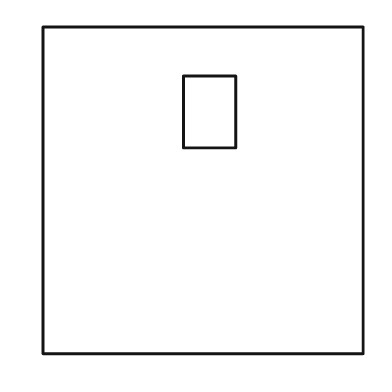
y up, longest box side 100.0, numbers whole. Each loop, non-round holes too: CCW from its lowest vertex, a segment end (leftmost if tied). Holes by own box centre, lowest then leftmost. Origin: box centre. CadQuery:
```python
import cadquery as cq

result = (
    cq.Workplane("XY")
    .moveTo(-49.0, -50.0)
    .lineTo(49.0, -50.0)
    .lineTo(49.0, 50.0)
    .lineTo(-49.0, 50.0)
    .close()
    .moveTo(-6.0, 13.0)
    .lineTo(10.0, 13.0)
    .lineTo(10.0, 35.0)
    .lineTo(-6.0, 35.0)
    .close()
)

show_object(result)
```